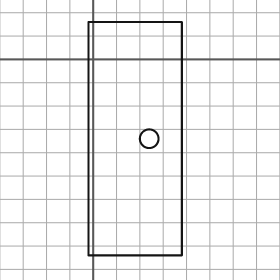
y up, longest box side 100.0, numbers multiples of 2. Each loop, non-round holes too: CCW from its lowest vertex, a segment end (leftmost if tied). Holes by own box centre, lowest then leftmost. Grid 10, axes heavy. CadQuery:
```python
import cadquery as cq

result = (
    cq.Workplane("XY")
    .moveTo(-2.0, -84.0)
    .lineTo(38.0, -84.0)
    .lineTo(38.0, 16.0)
    .lineTo(-2.0, 16.0)
    .close()
    .moveTo(24.0, -34.0)
    .circle(4.0)
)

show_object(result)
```